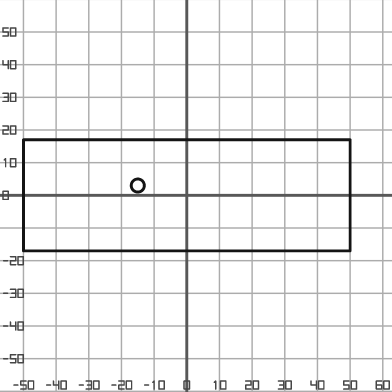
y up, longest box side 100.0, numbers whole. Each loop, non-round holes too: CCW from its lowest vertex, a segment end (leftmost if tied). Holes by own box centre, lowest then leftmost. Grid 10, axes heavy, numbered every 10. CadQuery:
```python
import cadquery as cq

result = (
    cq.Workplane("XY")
    .moveTo(-50.0, -17.0)
    .lineTo(50.0, -17.0)
    .lineTo(50.0, 17.0)
    .lineTo(-50.0, 17.0)
    .close()
    .moveTo(-15.0, 3.0)
    .circle(2.0)
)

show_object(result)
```